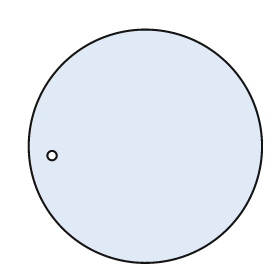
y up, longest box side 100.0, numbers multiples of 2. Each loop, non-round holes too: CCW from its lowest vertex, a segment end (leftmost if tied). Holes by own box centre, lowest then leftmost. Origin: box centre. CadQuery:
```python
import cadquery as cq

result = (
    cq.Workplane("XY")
    .moveTo(0.0, 0.0)
    .circle(50.0)
    .moveTo(-40.0, -4.0)
    .circle(2.0)
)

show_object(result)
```